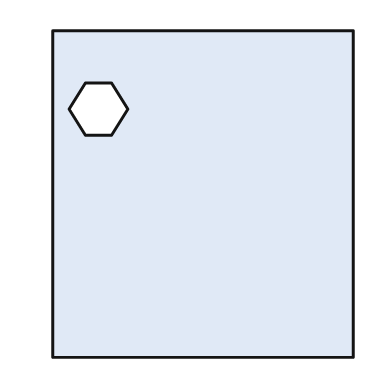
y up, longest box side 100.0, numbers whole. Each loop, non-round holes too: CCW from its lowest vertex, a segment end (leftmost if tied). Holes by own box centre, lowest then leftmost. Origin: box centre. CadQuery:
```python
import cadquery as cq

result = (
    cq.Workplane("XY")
    .moveTo(-46.0, -50.0)
    .lineTo(46.0, -50.0)
    .lineTo(46.0, 50.0)
    .lineTo(-46.0, 50.0)
    .close()
    .moveTo(-36.0, 18.0)
    .lineTo(-28.0, 18.0)
    .lineTo(-23.0, 26.0)
    .lineTo(-28.0, 34.0)
    .lineTo(-36.0, 34.0)
    .lineTo(-41.0, 26.0)
    .close()
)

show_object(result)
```